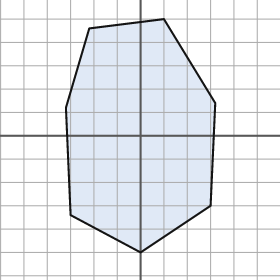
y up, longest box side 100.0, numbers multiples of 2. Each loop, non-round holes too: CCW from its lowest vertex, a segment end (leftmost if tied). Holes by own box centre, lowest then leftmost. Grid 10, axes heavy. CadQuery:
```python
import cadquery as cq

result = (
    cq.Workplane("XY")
    .moveTo(0.0, -50.0)
    .lineTo(30.0, -30.0)
    .lineTo(32.0, 14.0)
    .lineTo(10.0, 50.0)
    .lineTo(-22.0, 46.0)
    .lineTo(-32.0, 12.0)
    .lineTo(-30.0, -34.0)
    .close()
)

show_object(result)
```